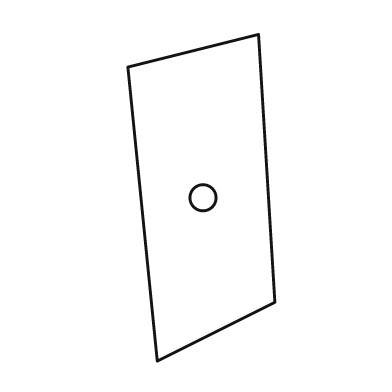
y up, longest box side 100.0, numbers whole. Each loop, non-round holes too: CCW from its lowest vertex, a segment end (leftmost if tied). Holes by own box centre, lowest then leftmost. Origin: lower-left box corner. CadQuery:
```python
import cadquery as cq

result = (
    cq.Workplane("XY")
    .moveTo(9.0, 0.0)
    .lineTo(45.0, 18.0)
    .lineTo(40.0, 100.0)
    .lineTo(0.0, 90.0)
    .close()
    .moveTo(23.0, 50.0)
    .circle(4.0)
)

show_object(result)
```